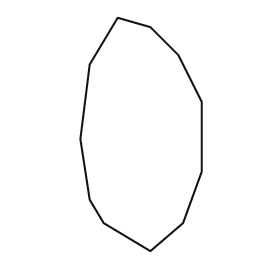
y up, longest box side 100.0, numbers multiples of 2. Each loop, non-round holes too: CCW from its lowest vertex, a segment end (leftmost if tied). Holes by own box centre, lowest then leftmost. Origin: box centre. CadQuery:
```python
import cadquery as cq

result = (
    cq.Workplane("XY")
    .moveTo(4.0, -50.0)
    .lineTo(18.0, -38.0)
    .lineTo(26.0, -16.0)
    .lineTo(26.0, 14.0)
    .lineTo(16.0, 34.0)
    .lineTo(4.0, 46.0)
    .lineTo(-10.0, 50.0)
    .lineTo(-22.0, 30.0)
    .lineTo(-26.0, -2.0)
    .lineTo(-22.0, -28.0)
    .lineTo(-16.0, -38.0)
    .close()
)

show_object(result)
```